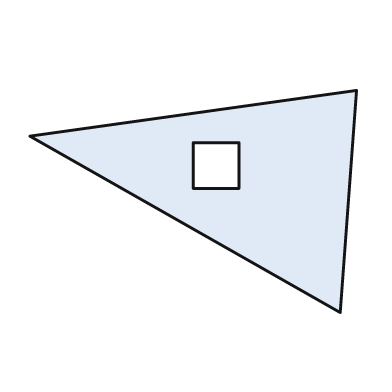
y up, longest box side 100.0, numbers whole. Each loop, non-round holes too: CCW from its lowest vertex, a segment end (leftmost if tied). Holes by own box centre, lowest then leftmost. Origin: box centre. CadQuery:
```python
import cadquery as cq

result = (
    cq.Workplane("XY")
    .moveTo(45.0, -34.0)
    .lineTo(50.0, 34.0)
    .lineTo(-50.0, 20.0)
    .close()
    .moveTo(0.0, 4.0)
    .lineTo(14.0, 4.0)
    .lineTo(14.0, 18.0)
    .lineTo(0.0, 18.0)
    .close()
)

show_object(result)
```